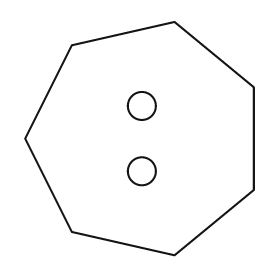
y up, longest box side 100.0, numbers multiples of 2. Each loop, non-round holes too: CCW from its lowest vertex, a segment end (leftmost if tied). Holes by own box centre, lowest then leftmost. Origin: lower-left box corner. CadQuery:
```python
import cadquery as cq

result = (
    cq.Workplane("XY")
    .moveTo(64.0, 0.0)
    .lineTo(98.0, 28.0)
    .lineTo(98.0, 72.0)
    .lineTo(64.0, 100.0)
    .lineTo(20.0, 90.0)
    .lineTo(0.0, 50.0)
    .lineTo(20.0, 10.0)
    .close()
    .moveTo(50.0, 36.0)
    .circle(6.0)
    .moveTo(50.0, 64.0)
    .circle(6.0)
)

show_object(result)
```